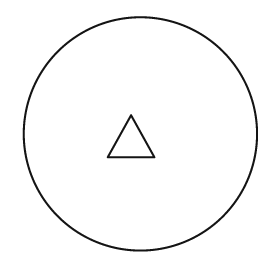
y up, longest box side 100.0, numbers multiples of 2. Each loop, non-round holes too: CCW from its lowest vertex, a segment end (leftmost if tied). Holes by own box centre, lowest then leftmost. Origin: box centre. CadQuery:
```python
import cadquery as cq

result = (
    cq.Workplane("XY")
    .moveTo(0.0, 0.0)
    .circle(50.0)
    .moveTo(-14.0, -10.0)
    .lineTo(6.0, -10.0)
    .lineTo(-4.0, 8.0)
    .close()
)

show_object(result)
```